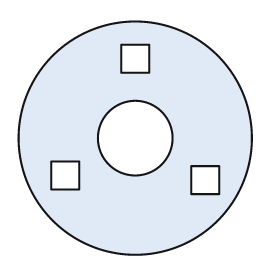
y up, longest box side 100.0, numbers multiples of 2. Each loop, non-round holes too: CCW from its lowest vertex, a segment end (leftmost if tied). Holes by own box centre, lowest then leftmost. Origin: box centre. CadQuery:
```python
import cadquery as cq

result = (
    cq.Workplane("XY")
    .moveTo(0.0, 0.0)
    .circle(50.0)
    .moveTo(24.0, -24.0)
    .lineTo(36.0, -24.0)
    .lineTo(36.0, -12.0)
    .lineTo(24.0, -12.0)
    .close()
    .moveTo(-36.0, -22.0)
    .lineTo(-24.0, -22.0)
    .lineTo(-24.0, -10.0)
    .lineTo(-36.0, -10.0)
    .close()
    .moveTo(0.0, 0.0)
    .circle(16.0)
    .moveTo(-6.0, 28.0)
    .lineTo(6.0, 28.0)
    .lineTo(6.0, 40.0)
    .lineTo(-6.0, 40.0)
    .close()
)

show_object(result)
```